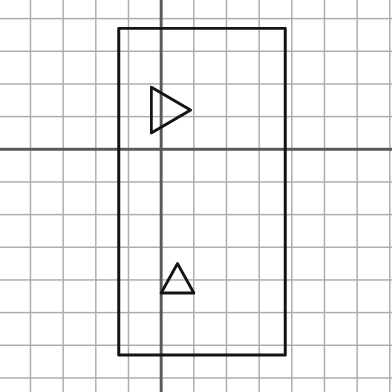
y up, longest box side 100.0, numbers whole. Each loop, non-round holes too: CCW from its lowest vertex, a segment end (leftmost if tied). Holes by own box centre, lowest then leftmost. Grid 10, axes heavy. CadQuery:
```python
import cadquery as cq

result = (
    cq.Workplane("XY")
    .moveTo(-13.0, -63.0)
    .lineTo(38.0, -63.0)
    .lineTo(38.0, 37.0)
    .lineTo(-13.0, 37.0)
    .close()
    .moveTo(0.0, -44.0)
    .lineTo(10.0, -44.0)
    .lineTo(5.0, -35.0)
    .close()
    .moveTo(-3.0, 5.0)
    .lineTo(9.0, 12.0)
    .lineTo(-3.0, 19.0)
    .close()
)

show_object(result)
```